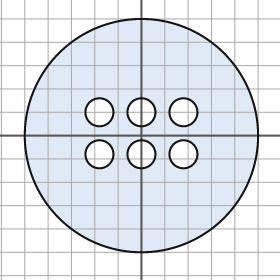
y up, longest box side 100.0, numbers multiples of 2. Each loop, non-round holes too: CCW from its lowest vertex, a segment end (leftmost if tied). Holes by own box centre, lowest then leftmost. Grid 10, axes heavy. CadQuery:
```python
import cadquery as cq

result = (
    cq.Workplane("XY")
    .moveTo(0.0, 0.0)
    .circle(50.0)
    .moveTo(-18.0, -8.0)
    .circle(6.0)
    .moveTo(0.0, -8.0)
    .circle(6.0)
    .moveTo(18.0, -8.0)
    .circle(6.0)
    .moveTo(-18.0, 10.0)
    .circle(6.0)
    .moveTo(0.0, 10.0)
    .circle(6.0)
    .moveTo(18.0, 10.0)
    .circle(6.0)
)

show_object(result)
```